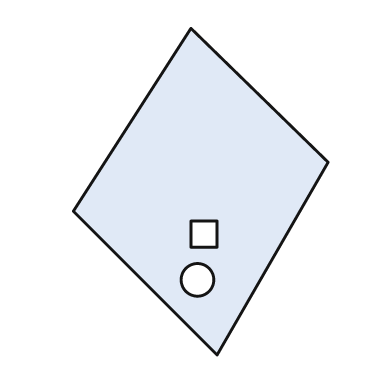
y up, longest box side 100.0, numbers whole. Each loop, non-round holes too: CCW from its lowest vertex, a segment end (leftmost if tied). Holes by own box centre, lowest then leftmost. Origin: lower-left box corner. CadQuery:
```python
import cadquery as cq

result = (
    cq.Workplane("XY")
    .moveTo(44.0, 0.0)
    .lineTo(78.0, 59.0)
    .lineTo(36.0, 100.0)
    .lineTo(0.0, 44.0)
    .close()
    .moveTo(38.0, 23.0)
    .circle(5.0)
    .moveTo(36.0, 33.0)
    .lineTo(44.0, 33.0)
    .lineTo(44.0, 41.0)
    .lineTo(36.0, 41.0)
    .close()
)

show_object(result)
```